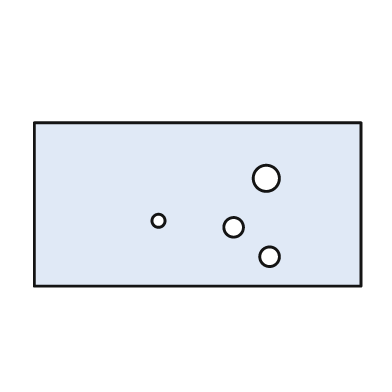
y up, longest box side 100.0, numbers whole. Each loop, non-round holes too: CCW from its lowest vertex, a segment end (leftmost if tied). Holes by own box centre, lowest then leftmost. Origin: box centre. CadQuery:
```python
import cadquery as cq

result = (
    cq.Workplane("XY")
    .moveTo(-50.0, -25.0)
    .lineTo(50.0, -25.0)
    .lineTo(50.0, 25.0)
    .lineTo(-50.0, 25.0)
    .close()
    .moveTo(22.0, -16.0)
    .circle(3.0)
    .moveTo(11.0, -7.0)
    .circle(3.0)
    .moveTo(-12.0, -5.0)
    .circle(2.0)
    .moveTo(21.0, 8.0)
    .circle(4.0)
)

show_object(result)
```